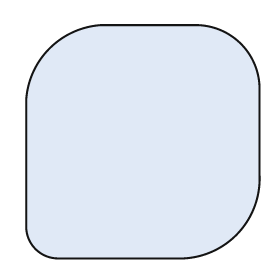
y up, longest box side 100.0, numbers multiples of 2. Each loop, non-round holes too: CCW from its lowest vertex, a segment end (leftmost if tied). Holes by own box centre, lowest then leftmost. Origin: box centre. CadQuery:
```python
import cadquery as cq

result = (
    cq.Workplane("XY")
    .moveTo(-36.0, -50.0)
    .lineTo(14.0, -50.0)
    .threePointArc((40.0, -40.0), (50.0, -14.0))
    .lineTo(50.0, 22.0)
    .threePointArc((42.0, 42.0), (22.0, 50.0))
    .lineTo(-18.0, 50.0)
    .threePointArc((-40.0, 40.0), (-50.0, 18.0))
    .lineTo(-50.0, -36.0)
    .threePointArc((-46.0, -46.0), (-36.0, -50.0))
    .close()
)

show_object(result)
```